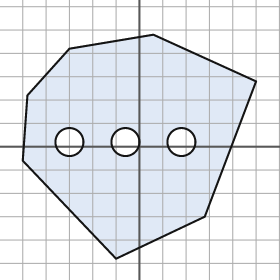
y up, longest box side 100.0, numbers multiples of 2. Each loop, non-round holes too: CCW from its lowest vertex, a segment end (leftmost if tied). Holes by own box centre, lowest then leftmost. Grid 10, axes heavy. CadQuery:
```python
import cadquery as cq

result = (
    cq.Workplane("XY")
    .moveTo(-10.0, -48.0)
    .lineTo(28.0, -30.0)
    .lineTo(50.0, 28.0)
    .lineTo(6.0, 48.0)
    .lineTo(-30.0, 42.0)
    .lineTo(-48.0, 22.0)
    .lineTo(-50.0, -6.0)
    .close()
    .moveTo(-30.0, 2.0)
    .circle(6.0)
    .moveTo(-6.0, 2.0)
    .circle(6.0)
    .moveTo(18.0, 2.0)
    .circle(6.0)
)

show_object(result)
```